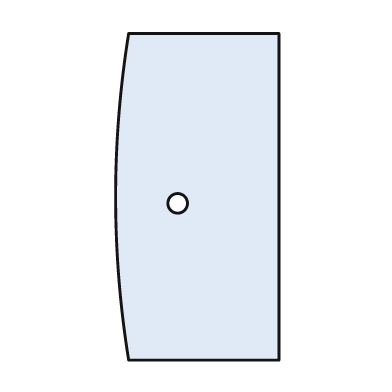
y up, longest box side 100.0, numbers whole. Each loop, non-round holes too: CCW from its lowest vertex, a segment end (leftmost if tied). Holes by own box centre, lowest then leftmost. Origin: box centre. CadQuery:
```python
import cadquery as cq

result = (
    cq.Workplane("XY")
    .moveTo(-21.0, -50.0)
    .lineTo(25.0, -50.0)
    .lineTo(25.0, 50.0)
    .lineTo(-21.0, 50.0)
    .threePointArc((-25.0, 0.0), (-21.0, -50.0))
    .close()
    .moveTo(-6.0, -2.0)
    .circle(3.0)
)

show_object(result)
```